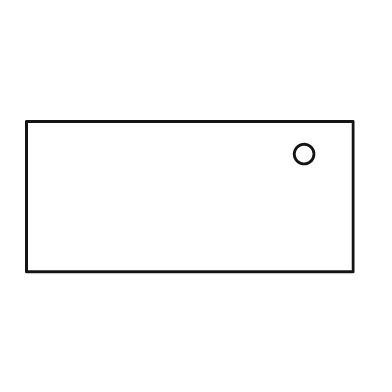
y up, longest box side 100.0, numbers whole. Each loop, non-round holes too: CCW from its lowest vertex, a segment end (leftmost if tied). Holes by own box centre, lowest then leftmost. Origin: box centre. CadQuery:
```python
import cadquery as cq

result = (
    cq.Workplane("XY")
    .moveTo(-50.0, -23.0)
    .lineTo(50.0, -23.0)
    .lineTo(50.0, 23.0)
    .lineTo(-50.0, 23.0)
    .close()
    .moveTo(35.0, 13.0)
    .circle(3.0)
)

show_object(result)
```